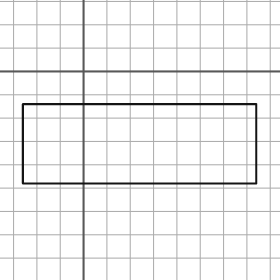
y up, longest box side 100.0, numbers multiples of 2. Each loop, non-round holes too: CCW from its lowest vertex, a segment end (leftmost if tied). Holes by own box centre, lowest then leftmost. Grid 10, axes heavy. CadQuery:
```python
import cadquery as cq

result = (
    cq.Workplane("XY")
    .moveTo(-26.0, -48.0)
    .lineTo(74.0, -48.0)
    .lineTo(74.0, -14.0)
    .lineTo(-26.0, -14.0)
    .close()
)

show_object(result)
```